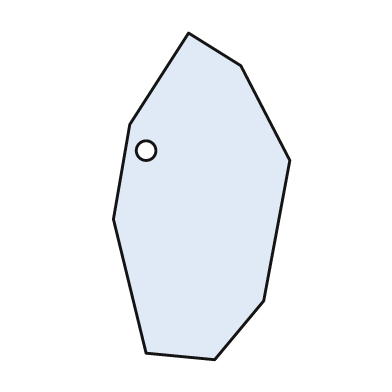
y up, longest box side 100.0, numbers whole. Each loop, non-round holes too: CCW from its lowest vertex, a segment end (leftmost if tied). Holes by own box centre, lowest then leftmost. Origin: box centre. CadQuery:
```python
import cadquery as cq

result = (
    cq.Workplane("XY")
    .moveTo(4.0, -50.0)
    .lineTo(19.0, -32.0)
    .lineTo(27.0, 11.0)
    .lineTo(12.0, 40.0)
    .lineTo(-4.0, 50.0)
    .lineTo(-22.0, 22.0)
    .lineTo(-27.0, -7.0)
    .lineTo(-17.0, -48.0)
    .close()
    .moveTo(-17.0, 14.0)
    .circle(3.0)
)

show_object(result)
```